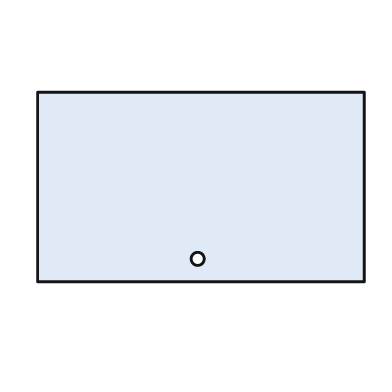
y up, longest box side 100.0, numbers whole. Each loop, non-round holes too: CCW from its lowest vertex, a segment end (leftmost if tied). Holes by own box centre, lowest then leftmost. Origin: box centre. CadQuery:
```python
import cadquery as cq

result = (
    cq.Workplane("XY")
    .moveTo(-50.0, -29.0)
    .lineTo(50.0, -29.0)
    .lineTo(50.0, 29.0)
    .lineTo(-50.0, 29.0)
    .close()
    .moveTo(-1.0, -22.0)
    .circle(2.0)
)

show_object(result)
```